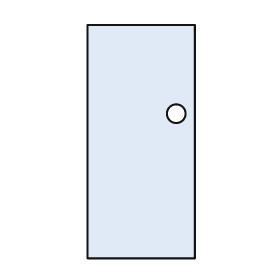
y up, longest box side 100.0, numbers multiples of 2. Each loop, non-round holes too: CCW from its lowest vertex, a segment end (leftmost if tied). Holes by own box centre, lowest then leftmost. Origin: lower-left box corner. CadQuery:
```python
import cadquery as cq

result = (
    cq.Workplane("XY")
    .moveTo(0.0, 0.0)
    .lineTo(46.0, 0.0)
    .lineTo(46.0, 100.0)
    .lineTo(0.0, 100.0)
    .close()
    .moveTo(38.0, 62.0)
    .circle(4.0)
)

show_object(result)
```